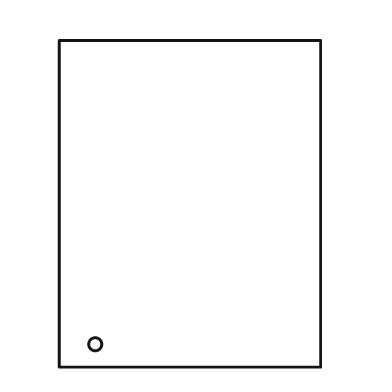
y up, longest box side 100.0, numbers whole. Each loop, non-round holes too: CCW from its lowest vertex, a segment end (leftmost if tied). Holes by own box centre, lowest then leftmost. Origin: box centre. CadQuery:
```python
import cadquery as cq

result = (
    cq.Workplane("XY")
    .moveTo(-40.0, -50.0)
    .lineTo(40.0, -50.0)
    .lineTo(40.0, 50.0)
    .lineTo(-40.0, 50.0)
    .close()
    .moveTo(-29.0, -43.0)
    .circle(2.0)
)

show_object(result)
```